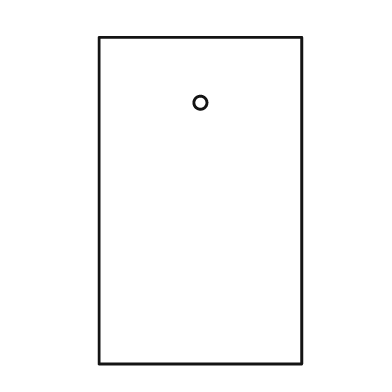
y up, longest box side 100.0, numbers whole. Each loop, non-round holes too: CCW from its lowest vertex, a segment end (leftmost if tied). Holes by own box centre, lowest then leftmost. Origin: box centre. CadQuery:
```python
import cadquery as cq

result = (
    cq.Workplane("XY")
    .moveTo(-31.0, -50.0)
    .lineTo(31.0, -50.0)
    .lineTo(31.0, 50.0)
    .lineTo(-31.0, 50.0)
    .close()
    .moveTo(0.0, 30.0)
    .circle(2.0)
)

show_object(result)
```